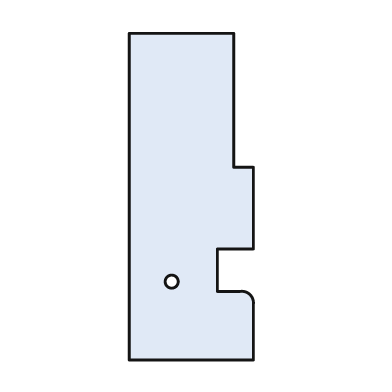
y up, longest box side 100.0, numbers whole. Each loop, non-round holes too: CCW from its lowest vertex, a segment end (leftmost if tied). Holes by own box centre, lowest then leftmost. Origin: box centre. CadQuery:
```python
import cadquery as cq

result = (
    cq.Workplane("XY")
    .moveTo(-19.0, -50.0)
    .lineTo(19.0, -50.0)
    .lineTo(19.0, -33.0)
    .threePointArc((18.0, -30.0), (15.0, -29.0))
    .lineTo(8.0, -29.0)
    .lineTo(8.0, -16.0)
    .lineTo(19.0, -16.0)
    .lineTo(19.0, 9.0)
    .lineTo(13.0, 9.0)
    .lineTo(13.0, 50.0)
    .lineTo(-19.0, 50.0)
    .close()
    .moveTo(-6.0, -26.0)
    .circle(2.0)
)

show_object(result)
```